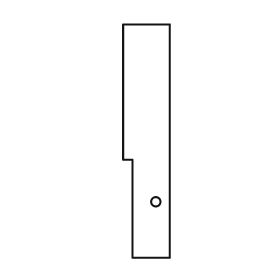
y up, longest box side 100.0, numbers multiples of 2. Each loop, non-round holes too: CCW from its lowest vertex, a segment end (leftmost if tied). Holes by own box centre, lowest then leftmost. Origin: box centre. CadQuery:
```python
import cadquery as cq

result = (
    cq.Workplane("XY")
    .moveTo(-6.0, -50.0)
    .lineTo(10.0, -50.0)
    .lineTo(10.0, 50.0)
    .lineTo(-10.0, 50.0)
    .lineTo(-10.0, -8.0)
    .lineTo(-6.0, -8.0)
    .close()
    .moveTo(4.0, -26.0)
    .circle(2.0)
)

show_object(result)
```